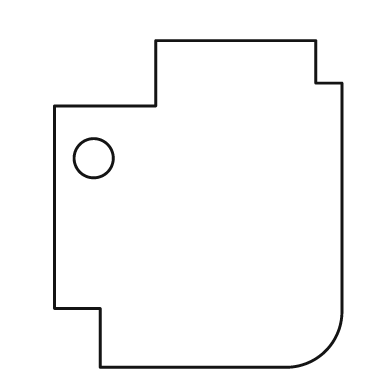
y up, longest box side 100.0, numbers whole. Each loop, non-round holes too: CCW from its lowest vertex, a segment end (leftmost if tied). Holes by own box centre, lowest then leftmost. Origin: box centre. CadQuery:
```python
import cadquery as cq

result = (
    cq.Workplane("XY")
    .moveTo(-30.0, -50.0)
    .lineTo(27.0, -50.0)
    .threePointArc((39.0, -45.0), (44.0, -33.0))
    .lineTo(44.0, 37.0)
    .lineTo(36.0, 37.0)
    .lineTo(36.0, 50.0)
    .lineTo(-13.0, 50.0)
    .lineTo(-13.0, 30.0)
    .lineTo(-44.0, 30.0)
    .lineTo(-44.0, -32.0)
    .lineTo(-30.0, -32.0)
    .close()
    .moveTo(-32.0, 14.0)
    .circle(6.0)
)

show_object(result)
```